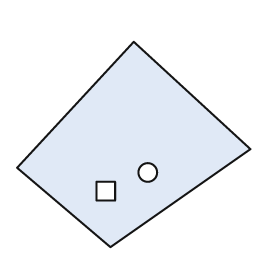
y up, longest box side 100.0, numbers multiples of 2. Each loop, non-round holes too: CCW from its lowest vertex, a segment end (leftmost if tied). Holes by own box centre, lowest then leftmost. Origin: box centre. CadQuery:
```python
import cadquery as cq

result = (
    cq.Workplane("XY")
    .moveTo(-10.0, -44.0)
    .lineTo(50.0, -2.0)
    .lineTo(0.0, 44.0)
    .lineTo(-50.0, -10.0)
    .close()
    .moveTo(-16.0, -24.0)
    .lineTo(-8.0, -24.0)
    .lineTo(-8.0, -16.0)
    .lineTo(-16.0, -16.0)
    .close()
    .moveTo(6.0, -12.0)
    .circle(4.0)
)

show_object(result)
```